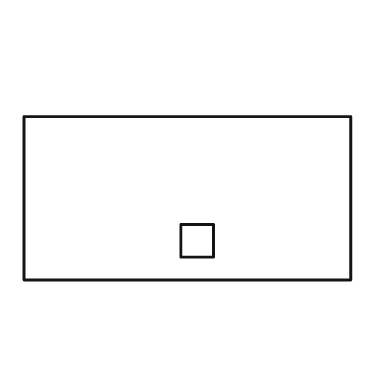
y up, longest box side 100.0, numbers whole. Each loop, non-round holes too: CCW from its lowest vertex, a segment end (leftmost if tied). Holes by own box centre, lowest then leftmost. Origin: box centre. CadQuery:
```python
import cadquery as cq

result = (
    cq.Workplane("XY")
    .moveTo(-50.0, -25.0)
    .lineTo(50.0, -25.0)
    .lineTo(50.0, 25.0)
    .lineTo(-50.0, 25.0)
    .close()
    .moveTo(-2.0, -18.0)
    .lineTo(8.0, -18.0)
    .lineTo(8.0, -8.0)
    .lineTo(-2.0, -8.0)
    .close()
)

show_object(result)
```